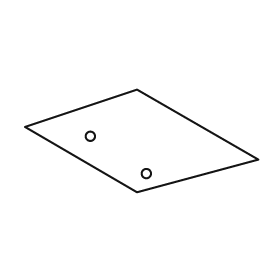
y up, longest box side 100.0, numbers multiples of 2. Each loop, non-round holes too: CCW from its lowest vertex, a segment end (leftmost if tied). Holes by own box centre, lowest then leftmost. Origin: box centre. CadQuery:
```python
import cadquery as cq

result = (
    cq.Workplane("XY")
    .moveTo(-2.0, -22.0)
    .lineTo(50.0, -8.0)
    .lineTo(-2.0, 22.0)
    .lineTo(-50.0, 6.0)
    .close()
    .moveTo(2.0, -14.0)
    .circle(2.0)
    .moveTo(-22.0, 2.0)
    .circle(2.0)
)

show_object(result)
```